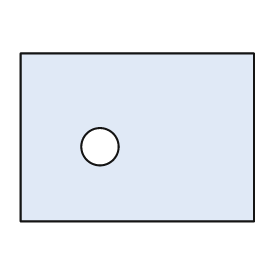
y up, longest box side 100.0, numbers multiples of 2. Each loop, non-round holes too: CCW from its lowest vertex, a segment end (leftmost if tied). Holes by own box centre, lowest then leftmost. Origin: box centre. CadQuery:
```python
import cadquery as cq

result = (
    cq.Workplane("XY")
    .moveTo(-50.0, -36.0)
    .lineTo(50.0, -36.0)
    .lineTo(50.0, 36.0)
    .lineTo(-50.0, 36.0)
    .close()
    .moveTo(-16.0, -4.0)
    .circle(8.0)
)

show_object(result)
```